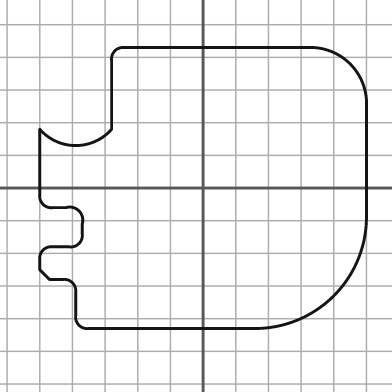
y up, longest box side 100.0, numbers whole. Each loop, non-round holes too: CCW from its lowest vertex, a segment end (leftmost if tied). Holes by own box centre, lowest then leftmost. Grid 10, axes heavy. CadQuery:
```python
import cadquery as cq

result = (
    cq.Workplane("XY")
    .moveTo(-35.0, -43.0)
    .lineTo(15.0, -43.0)
    .threePointArc((40.0, -33.0), (50.0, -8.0))
    .lineTo(50.0, 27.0)
    .threePointArc((45.0, 38.0), (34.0, 43.0))
    .lineTo(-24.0, 43.0)
    .threePointArc((-27.0, 42.0), (-28.0, 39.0))
    .lineTo(-28.0, 18.0)
    .threePointArc((-39.0, 13.0), (-50.0, 18.0))
    .lineTo(-50.0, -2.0)
    .threePointArc((-49.0, -5.0), (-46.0, -6.0))
    .lineTo(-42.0, -6.0)
    .threePointArc((-38.0, -7.0), (-37.0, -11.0))
    .lineTo(-37.0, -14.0)
    .threePointArc((-38.0, -17.0), (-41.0, -18.0))
    .lineTo(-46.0, -18.0)
    .threePointArc((-49.0, -19.0), (-50.0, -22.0))
    .lineTo(-50.0, -25.0)
    .lineTo(-47.0, -28.0)
    .lineTo(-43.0, -28.0)
    .threePointArc((-40.0, -29.0), (-39.0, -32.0))
    .lineTo(-39.0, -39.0)
    .threePointArc((-38.0, -42.0), (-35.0, -43.0))
    .close()
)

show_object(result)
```